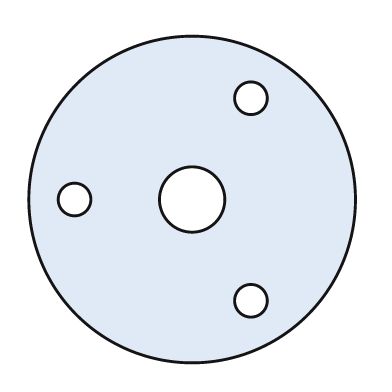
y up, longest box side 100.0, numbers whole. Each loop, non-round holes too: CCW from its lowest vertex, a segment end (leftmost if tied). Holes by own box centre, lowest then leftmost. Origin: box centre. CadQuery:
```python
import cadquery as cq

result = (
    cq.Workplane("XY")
    .moveTo(0.0, 0.0)
    .circle(50.0)
    .moveTo(18.0, -31.0)
    .circle(5.0)
    .moveTo(-36.0, 0.0)
    .circle(5.0)
    .moveTo(0.0, 0.0)
    .circle(10.0)
    .moveTo(18.0, 31.0)
    .circle(5.0)
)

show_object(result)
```